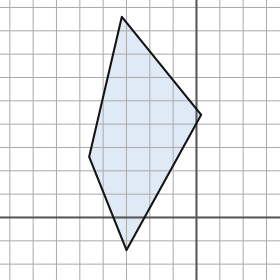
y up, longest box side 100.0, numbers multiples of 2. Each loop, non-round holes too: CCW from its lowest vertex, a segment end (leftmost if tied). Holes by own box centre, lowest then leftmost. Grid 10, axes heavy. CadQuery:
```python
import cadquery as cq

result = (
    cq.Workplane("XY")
    .moveTo(-30.0, -14.0)
    .lineTo(2.0, 44.0)
    .lineTo(-32.0, 86.0)
    .lineTo(-46.0, 26.0)
    .close()
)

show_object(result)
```